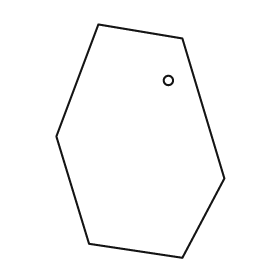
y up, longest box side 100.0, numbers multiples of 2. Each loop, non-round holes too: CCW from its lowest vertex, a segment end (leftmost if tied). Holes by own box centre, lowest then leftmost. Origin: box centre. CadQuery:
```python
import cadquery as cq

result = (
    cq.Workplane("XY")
    .moveTo(18.0, -50.0)
    .lineTo(36.0, -16.0)
    .lineTo(18.0, 44.0)
    .lineTo(-18.0, 50.0)
    .lineTo(-36.0, 2.0)
    .lineTo(-22.0, -44.0)
    .close()
    .moveTo(12.0, 26.0)
    .circle(2.0)
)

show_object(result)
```